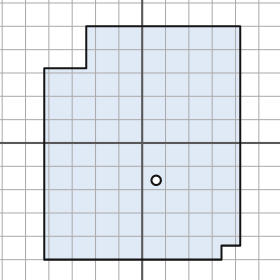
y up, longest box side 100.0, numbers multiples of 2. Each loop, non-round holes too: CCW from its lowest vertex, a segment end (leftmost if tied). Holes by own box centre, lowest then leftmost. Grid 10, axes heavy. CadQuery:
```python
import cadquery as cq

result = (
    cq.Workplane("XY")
    .moveTo(-42.0, -50.0)
    .lineTo(34.0, -50.0)
    .lineTo(34.0, -44.0)
    .lineTo(42.0, -44.0)
    .lineTo(42.0, 50.0)
    .lineTo(-24.0, 50.0)
    .lineTo(-24.0, 32.0)
    .lineTo(-42.0, 32.0)
    .close()
    .moveTo(6.0, -16.0)
    .circle(2.0)
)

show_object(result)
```